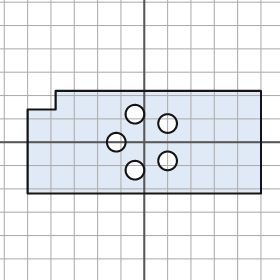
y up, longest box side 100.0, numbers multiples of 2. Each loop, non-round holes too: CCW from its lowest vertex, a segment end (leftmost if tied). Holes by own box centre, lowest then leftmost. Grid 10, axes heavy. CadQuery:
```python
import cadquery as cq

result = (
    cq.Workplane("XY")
    .moveTo(-50.0, -22.0)
    .lineTo(50.0, -22.0)
    .lineTo(50.0, 22.0)
    .lineTo(-38.0, 22.0)
    .lineTo(-38.0, 14.0)
    .lineTo(-50.0, 14.0)
    .close()
    .moveTo(-4.0, -12.0)
    .circle(4.0)
    .moveTo(10.0, -8.0)
    .circle(4.0)
    .moveTo(-12.0, 0.0)
    .circle(4.0)
    .moveTo(10.0, 8.0)
    .circle(4.0)
    .moveTo(-4.0, 12.0)
    .circle(4.0)
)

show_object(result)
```